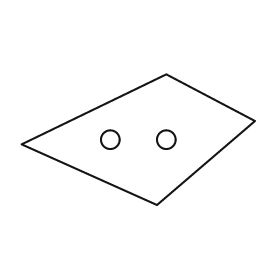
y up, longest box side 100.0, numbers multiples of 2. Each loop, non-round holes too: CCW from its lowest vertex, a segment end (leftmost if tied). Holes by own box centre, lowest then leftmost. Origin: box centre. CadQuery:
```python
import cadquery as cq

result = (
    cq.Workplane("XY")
    .moveTo(8.0, -28.0)
    .lineTo(50.0, 8.0)
    .lineTo(12.0, 28.0)
    .lineTo(-50.0, -2.0)
    .close()
    .moveTo(-12.0, 0.0)
    .circle(4.0)
    .moveTo(12.0, 0.0)
    .circle(4.0)
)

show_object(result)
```